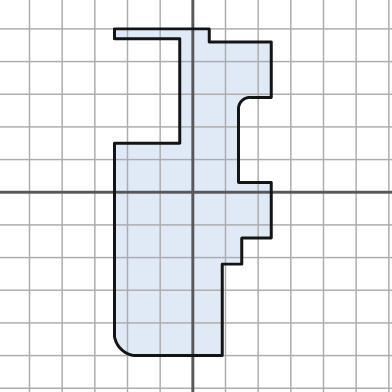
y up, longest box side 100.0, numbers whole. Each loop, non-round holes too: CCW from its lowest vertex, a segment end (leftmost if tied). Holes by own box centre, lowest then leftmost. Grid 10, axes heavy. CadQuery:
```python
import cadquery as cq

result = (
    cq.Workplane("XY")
    .moveTo(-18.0, -50.0)
    .lineTo(9.0, -50.0)
    .lineTo(9.0, -22.0)
    .lineTo(15.0, -22.0)
    .lineTo(15.0, -14.0)
    .lineTo(24.0, -14.0)
    .lineTo(24.0, 3.0)
    .lineTo(14.0, 3.0)
    .lineTo(14.0, 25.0)
    .threePointArc((15.0, 28.0), (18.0, 29.0))
    .lineTo(24.0, 29.0)
    .lineTo(24.0, 46.0)
    .lineTo(5.0, 46.0)
    .lineTo(5.0, 50.0)
    .lineTo(-24.0, 50.0)
    .lineTo(-24.0, 47.0)
    .lineTo(-4.0, 47.0)
    .lineTo(-4.0, 15.0)
    .lineTo(-24.0, 15.0)
    .lineTo(-24.0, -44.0)
    .threePointArc((-22.0, -48.0), (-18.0, -50.0))
    .close()
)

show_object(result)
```